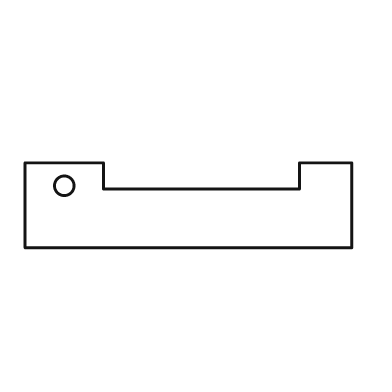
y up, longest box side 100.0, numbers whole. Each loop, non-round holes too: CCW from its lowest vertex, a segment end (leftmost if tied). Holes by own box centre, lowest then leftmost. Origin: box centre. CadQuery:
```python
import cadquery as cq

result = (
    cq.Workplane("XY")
    .moveTo(-50.0, -13.0)
    .lineTo(50.0, -13.0)
    .lineTo(50.0, 13.0)
    .lineTo(34.0, 13.0)
    .lineTo(34.0, 5.0)
    .lineTo(-26.0, 5.0)
    .lineTo(-26.0, 13.0)
    .lineTo(-50.0, 13.0)
    .close()
    .moveTo(-38.0, 6.0)
    .circle(3.0)
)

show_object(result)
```